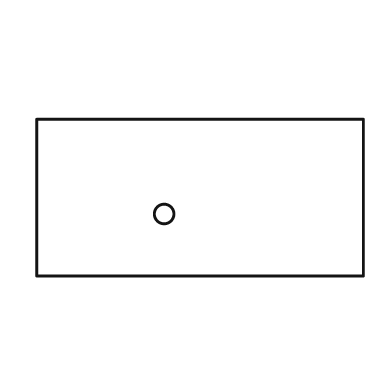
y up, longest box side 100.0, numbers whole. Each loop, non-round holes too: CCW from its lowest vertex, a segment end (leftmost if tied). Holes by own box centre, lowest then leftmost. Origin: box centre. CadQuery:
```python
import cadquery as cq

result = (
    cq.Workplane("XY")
    .moveTo(-50.0, -24.0)
    .lineTo(50.0, -24.0)
    .lineTo(50.0, 24.0)
    .lineTo(-50.0, 24.0)
    .close()
    .moveTo(-11.0, -5.0)
    .circle(3.0)
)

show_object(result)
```